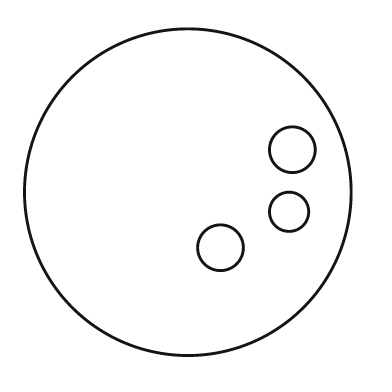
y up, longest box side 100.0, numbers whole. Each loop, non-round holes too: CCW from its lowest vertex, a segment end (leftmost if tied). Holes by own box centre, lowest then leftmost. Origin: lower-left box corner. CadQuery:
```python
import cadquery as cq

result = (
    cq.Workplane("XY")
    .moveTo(50.0, 50.0)
    .circle(50.0)
    .moveTo(60.0, 33.0)
    .circle(7.0)
    .moveTo(81.0, 44.0)
    .circle(6.0)
    .moveTo(82.0, 63.0)
    .circle(7.0)
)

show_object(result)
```